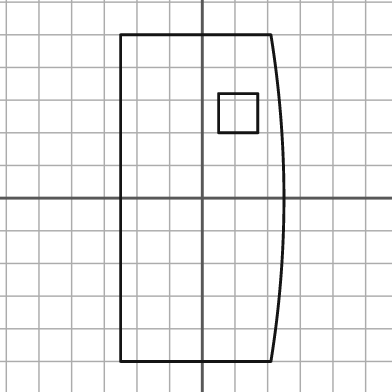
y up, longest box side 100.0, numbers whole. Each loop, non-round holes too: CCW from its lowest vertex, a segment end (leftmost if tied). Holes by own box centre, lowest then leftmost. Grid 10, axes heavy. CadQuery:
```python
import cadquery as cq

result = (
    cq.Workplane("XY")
    .moveTo(-25.0, -50.0)
    .lineTo(21.0, -50.0)
    .threePointArc((25.0, 0.0), (21.0, 50.0))
    .lineTo(-25.0, 50.0)
    .close()
    .moveTo(5.0, 20.0)
    .lineTo(17.0, 20.0)
    .lineTo(17.0, 32.0)
    .lineTo(5.0, 32.0)
    .close()
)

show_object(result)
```